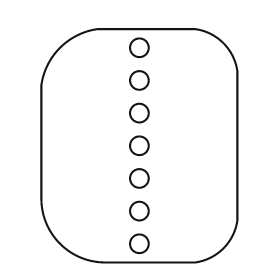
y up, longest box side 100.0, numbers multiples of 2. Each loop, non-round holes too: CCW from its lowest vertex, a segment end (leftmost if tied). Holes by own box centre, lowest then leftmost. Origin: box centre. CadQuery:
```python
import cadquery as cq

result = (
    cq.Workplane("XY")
    .moveTo(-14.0, -50.0)
    .lineTo(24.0, -50.0)
    .threePointArc((36.0, -44.0), (42.0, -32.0))
    .lineTo(42.0, 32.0)
    .threePointArc((36.0, 44.0), (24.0, 50.0))
    .lineTo(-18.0, 50.0)
    .threePointArc((-34.0, 42.0), (-42.0, 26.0))
    .lineTo(-42.0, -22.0)
    .threePointArc((-34.0, -42.0), (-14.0, -50.0))
    .close()
    .moveTo(0.0, -42.0)
    .circle(4.0)
    .moveTo(0.0, -28.0)
    .circle(4.0)
    .moveTo(0.0, -14.0)
    .circle(4.0)
    .moveTo(0.0, 0.0)
    .circle(4.0)
    .moveTo(0.0, 14.0)
    .circle(4.0)
    .moveTo(0.0, 28.0)
    .circle(4.0)
    .moveTo(0.0, 42.0)
    .circle(4.0)
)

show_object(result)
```